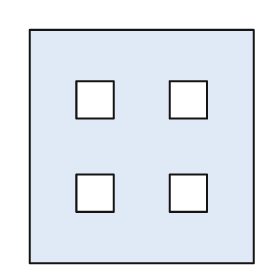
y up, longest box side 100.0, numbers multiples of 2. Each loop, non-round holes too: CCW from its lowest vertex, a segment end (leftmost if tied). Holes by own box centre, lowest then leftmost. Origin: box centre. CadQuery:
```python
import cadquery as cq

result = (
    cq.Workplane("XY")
    .moveTo(-48.0, -50.0)
    .lineTo(48.0, -50.0)
    .lineTo(48.0, 50.0)
    .lineTo(-48.0, 50.0)
    .close()
    .moveTo(-28.0, -28.0)
    .lineTo(-12.0, -28.0)
    .lineTo(-12.0, -12.0)
    .lineTo(-28.0, -12.0)
    .close()
    .moveTo(12.0, -28.0)
    .lineTo(28.0, -28.0)
    .lineTo(28.0, -12.0)
    .lineTo(12.0, -12.0)
    .close()
    .moveTo(-28.0, 12.0)
    .lineTo(-12.0, 12.0)
    .lineTo(-12.0, 28.0)
    .lineTo(-28.0, 28.0)
    .close()
    .moveTo(12.0, 12.0)
    .lineTo(28.0, 12.0)
    .lineTo(28.0, 28.0)
    .lineTo(12.0, 28.0)
    .close()
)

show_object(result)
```